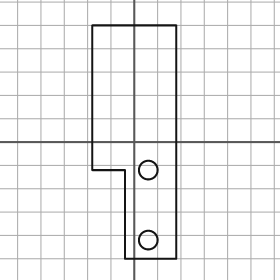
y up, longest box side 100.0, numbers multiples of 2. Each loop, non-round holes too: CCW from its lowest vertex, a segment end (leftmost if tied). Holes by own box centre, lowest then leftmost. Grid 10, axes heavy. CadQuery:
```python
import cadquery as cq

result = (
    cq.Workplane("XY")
    .moveTo(-4.0, -50.0)
    .lineTo(18.0, -50.0)
    .lineTo(18.0, 50.0)
    .lineTo(-18.0, 50.0)
    .lineTo(-18.0, -12.0)
    .lineTo(-4.0, -12.0)
    .close()
    .moveTo(6.0, -42.0)
    .circle(4.0)
    .moveTo(6.0, -12.0)
    .circle(4.0)
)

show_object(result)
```